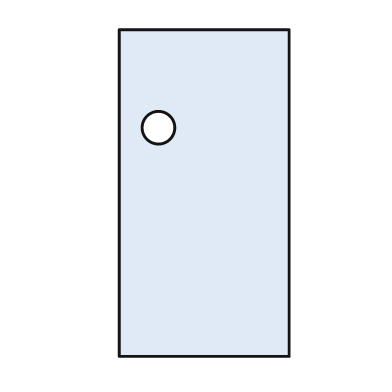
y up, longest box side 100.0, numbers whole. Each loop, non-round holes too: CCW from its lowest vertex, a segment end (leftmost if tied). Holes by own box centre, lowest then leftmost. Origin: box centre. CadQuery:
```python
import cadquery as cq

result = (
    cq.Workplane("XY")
    .moveTo(-26.0, -50.0)
    .lineTo(26.0, -50.0)
    .lineTo(26.0, 50.0)
    .lineTo(-26.0, 50.0)
    .close()
    .moveTo(-14.0, 20.0)
    .circle(5.0)
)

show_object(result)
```